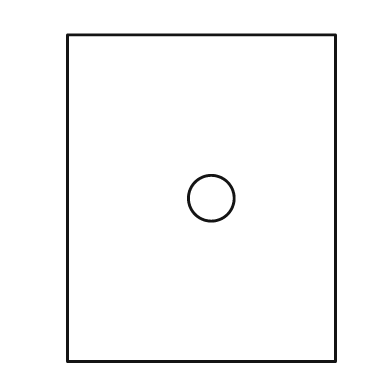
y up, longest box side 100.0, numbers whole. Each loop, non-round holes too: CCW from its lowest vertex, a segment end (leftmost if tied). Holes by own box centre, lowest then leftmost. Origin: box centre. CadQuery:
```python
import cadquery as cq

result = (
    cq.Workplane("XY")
    .moveTo(-41.0, -50.0)
    .lineTo(41.0, -50.0)
    .lineTo(41.0, 50.0)
    .lineTo(-41.0, 50.0)
    .close()
    .moveTo(3.0, 0.0)
    .circle(7.0)
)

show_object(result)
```